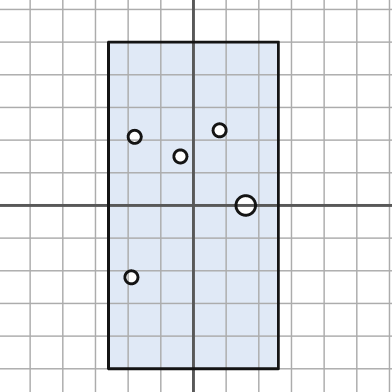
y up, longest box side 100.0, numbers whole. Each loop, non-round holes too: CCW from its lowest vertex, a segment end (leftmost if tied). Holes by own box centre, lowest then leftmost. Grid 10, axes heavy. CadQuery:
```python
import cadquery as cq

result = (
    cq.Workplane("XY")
    .moveTo(-26.0, -50.0)
    .lineTo(26.0, -50.0)
    .lineTo(26.0, 50.0)
    .lineTo(-26.0, 50.0)
    .close()
    .moveTo(-19.0, -22.0)
    .circle(2.0)
    .moveTo(16.0, 0.0)
    .circle(3.0)
    .moveTo(-4.0, 15.0)
    .circle(2.0)
    .moveTo(-18.0, 21.0)
    .circle(2.0)
    .moveTo(8.0, 23.0)
    .circle(2.0)
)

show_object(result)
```